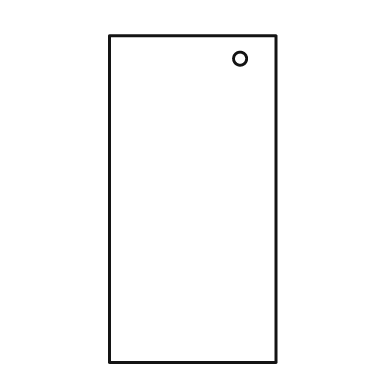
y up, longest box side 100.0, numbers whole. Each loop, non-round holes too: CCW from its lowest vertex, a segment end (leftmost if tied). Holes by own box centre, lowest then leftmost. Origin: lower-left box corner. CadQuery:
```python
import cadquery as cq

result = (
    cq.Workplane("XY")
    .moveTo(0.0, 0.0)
    .lineTo(51.0, 0.0)
    .lineTo(51.0, 100.0)
    .lineTo(0.0, 100.0)
    .close()
    .moveTo(40.0, 93.0)
    .circle(2.0)
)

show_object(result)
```